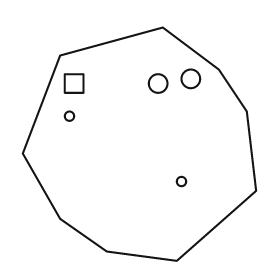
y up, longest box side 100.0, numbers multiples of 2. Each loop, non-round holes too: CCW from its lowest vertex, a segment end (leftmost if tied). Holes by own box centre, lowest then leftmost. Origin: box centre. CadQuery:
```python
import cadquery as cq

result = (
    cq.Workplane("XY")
    .moveTo(16.0, -50.0)
    .lineTo(50.0, -20.0)
    .lineTo(46.0, 14.0)
    .lineTo(34.0, 32.0)
    .lineTo(10.0, 50.0)
    .lineTo(-34.0, 38.0)
    .lineTo(-50.0, -4.0)
    .lineTo(-34.0, -32.0)
    .lineTo(-14.0, -46.0)
    .close()
    .moveTo(18.0, -16.0)
    .circle(2.0)
    .moveTo(-30.0, 12.0)
    .circle(2.0)
    .moveTo(-32.0, 22.0)
    .lineTo(-24.0, 22.0)
    .lineTo(-24.0, 30.0)
    .lineTo(-32.0, 30.0)
    .close()
    .moveTo(8.0, 26.0)
    .circle(4.0)
    .moveTo(22.0, 28.0)
    .circle(4.0)
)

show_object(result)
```